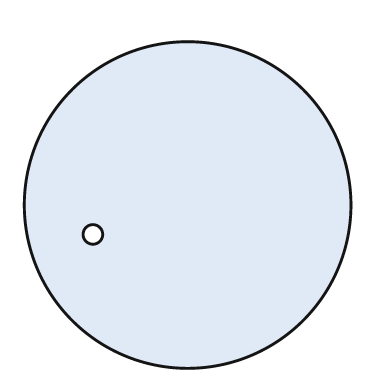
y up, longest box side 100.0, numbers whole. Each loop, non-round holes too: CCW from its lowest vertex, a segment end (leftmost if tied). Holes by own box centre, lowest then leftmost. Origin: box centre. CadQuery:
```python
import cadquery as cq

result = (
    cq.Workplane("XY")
    .moveTo(0.0, 0.0)
    .circle(50.0)
    .moveTo(-29.0, -9.0)
    .circle(3.0)
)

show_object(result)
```